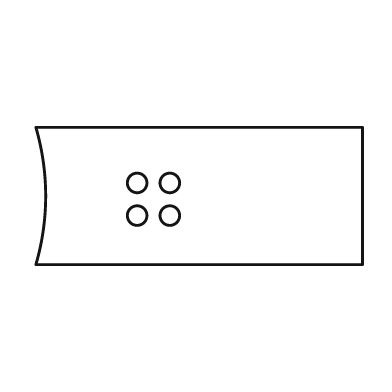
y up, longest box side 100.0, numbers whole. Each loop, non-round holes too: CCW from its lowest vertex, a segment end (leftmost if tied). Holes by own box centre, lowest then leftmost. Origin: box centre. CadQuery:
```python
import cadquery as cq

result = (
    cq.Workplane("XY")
    .moveTo(-50.0, -21.0)
    .lineTo(50.0, -21.0)
    .lineTo(50.0, 21.0)
    .lineTo(-50.0, 21.0)
    .threePointArc((-47.0, 0.0), (-50.0, -21.0))
    .close()
    .moveTo(-19.0, -6.0)
    .circle(3.0)
    .moveTo(-9.0, -6.0)
    .circle(3.0)
    .moveTo(-19.0, 4.0)
    .circle(3.0)
    .moveTo(-9.0, 4.0)
    .circle(3.0)
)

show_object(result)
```